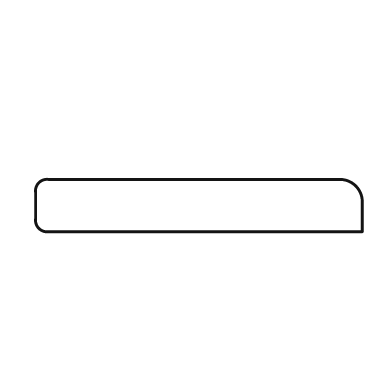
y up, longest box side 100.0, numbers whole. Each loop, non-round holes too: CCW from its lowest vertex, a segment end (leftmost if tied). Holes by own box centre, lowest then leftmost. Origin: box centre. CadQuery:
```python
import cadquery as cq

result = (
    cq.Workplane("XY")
    .moveTo(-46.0, -8.0)
    .lineTo(50.0, -8.0)
    .lineTo(50.0, 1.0)
    .threePointArc((48.0, 6.0), (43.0, 8.0))
    .lineTo(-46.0, 8.0)
    .threePointArc((-49.0, 7.0), (-50.0, 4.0))
    .lineTo(-50.0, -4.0)
    .threePointArc((-49.0, -7.0), (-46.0, -8.0))
    .close()
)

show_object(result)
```